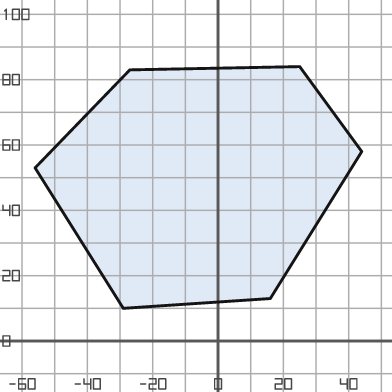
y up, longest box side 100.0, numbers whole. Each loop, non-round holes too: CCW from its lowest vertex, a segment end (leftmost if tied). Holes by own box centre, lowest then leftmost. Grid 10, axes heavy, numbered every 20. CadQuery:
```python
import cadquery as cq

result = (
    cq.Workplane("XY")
    .moveTo(-29.0, 10.0)
    .lineTo(16.0, 13.0)
    .lineTo(44.0, 58.0)
    .lineTo(25.0, 84.0)
    .lineTo(-27.0, 83.0)
    .lineTo(-56.0, 53.0)
    .close()
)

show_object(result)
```